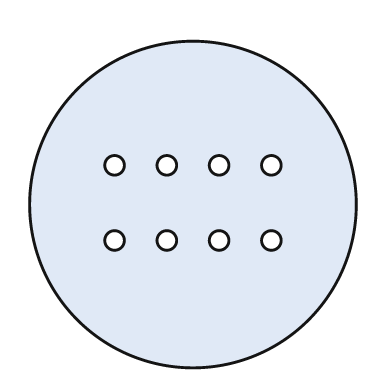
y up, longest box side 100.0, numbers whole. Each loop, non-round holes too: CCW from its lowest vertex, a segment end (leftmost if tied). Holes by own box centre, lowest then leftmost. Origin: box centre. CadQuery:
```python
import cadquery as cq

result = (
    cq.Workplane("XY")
    .moveTo(0.0, 0.0)
    .circle(50.0)
    .moveTo(-24.0, -11.0)
    .circle(3.0)
    .moveTo(-8.0, -11.0)
    .circle(3.0)
    .moveTo(8.0, -11.0)
    .circle(3.0)
    .moveTo(24.0, -11.0)
    .circle(3.0)
    .moveTo(-24.0, 12.0)
    .circle(3.0)
    .moveTo(-8.0, 12.0)
    .circle(3.0)
    .moveTo(8.0, 12.0)
    .circle(3.0)
    .moveTo(24.0, 12.0)
    .circle(3.0)
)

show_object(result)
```